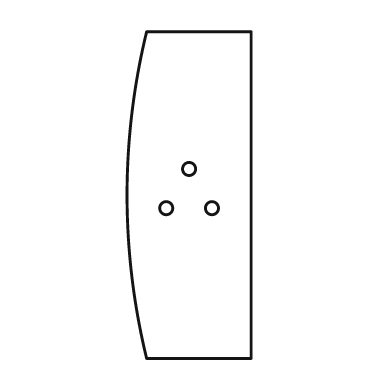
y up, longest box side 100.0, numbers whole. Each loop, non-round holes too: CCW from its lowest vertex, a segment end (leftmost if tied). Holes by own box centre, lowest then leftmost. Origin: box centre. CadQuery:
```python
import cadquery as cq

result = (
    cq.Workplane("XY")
    .moveTo(-13.0, -50.0)
    .lineTo(19.0, -50.0)
    .lineTo(19.0, 50.0)
    .lineTo(-13.0, 50.0)
    .threePointArc((-19.0, 0.0), (-13.0, -50.0))
    .close()
    .moveTo(-7.0, -4.0)
    .circle(2.0)
    .moveTo(7.0, -4.0)
    .circle(2.0)
    .moveTo(0.0, 8.0)
    .circle(2.0)
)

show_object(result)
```